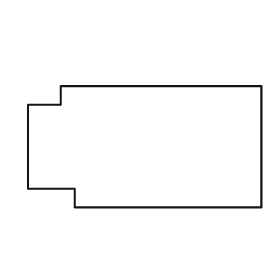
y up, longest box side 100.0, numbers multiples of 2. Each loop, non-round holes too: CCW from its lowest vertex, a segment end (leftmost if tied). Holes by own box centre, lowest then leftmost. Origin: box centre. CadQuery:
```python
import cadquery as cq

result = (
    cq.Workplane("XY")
    .moveTo(-30.0, -26.0)
    .lineTo(50.0, -26.0)
    .lineTo(50.0, 26.0)
    .lineTo(-36.0, 26.0)
    .lineTo(-36.0, 18.0)
    .lineTo(-50.0, 18.0)
    .lineTo(-50.0, -18.0)
    .lineTo(-30.0, -18.0)
    .close()
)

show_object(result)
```